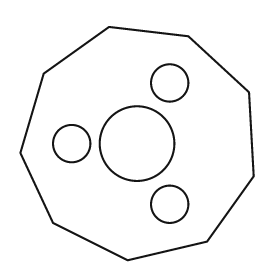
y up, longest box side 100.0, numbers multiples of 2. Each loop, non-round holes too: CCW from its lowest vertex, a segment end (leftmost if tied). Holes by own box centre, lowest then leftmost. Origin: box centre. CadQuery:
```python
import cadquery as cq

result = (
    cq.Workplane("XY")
    .moveTo(-4.0, -50.0)
    .lineTo(30.0, -42.0)
    .lineTo(50.0, -14.0)
    .lineTo(48.0, 22.0)
    .lineTo(22.0, 46.0)
    .lineTo(-12.0, 50.0)
    .lineTo(-40.0, 30.0)
    .lineTo(-50.0, -4.0)
    .lineTo(-36.0, -34.0)
    .close()
    .moveTo(14.0, -26.0)
    .circle(8.0)
    .moveTo(-28.0, 0.0)
    .circle(8.0)
    .moveTo(0.0, 0.0)
    .circle(16.0)
    .moveTo(14.0, 26.0)
    .circle(8.0)
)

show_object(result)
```